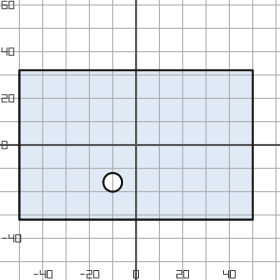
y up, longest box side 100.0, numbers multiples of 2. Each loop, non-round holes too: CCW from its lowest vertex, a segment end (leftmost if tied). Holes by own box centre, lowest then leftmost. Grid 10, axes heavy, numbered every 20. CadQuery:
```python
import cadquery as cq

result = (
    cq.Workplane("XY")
    .moveTo(-50.0, -32.0)
    .lineTo(50.0, -32.0)
    .lineTo(50.0, 32.0)
    .lineTo(-50.0, 32.0)
    .close()
    .moveTo(-10.0, -16.0)
    .circle(4.0)
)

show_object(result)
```